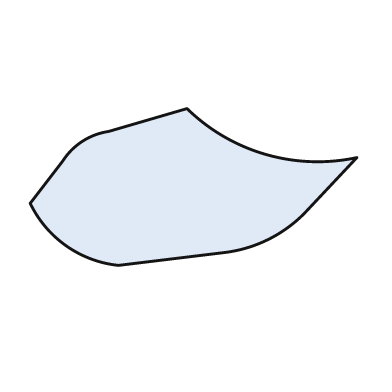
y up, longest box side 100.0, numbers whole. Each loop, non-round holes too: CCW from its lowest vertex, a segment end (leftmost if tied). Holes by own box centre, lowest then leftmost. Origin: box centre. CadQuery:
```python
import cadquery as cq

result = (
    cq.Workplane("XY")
    .moveTo(-23.0, -24.0)
    .lineTo(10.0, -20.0)
    .threePointArc((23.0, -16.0), (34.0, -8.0))
    .lineTo(50.0, 9.0)
    .threePointArc((22.0, 10.0), (-2.0, 24.0))
    .lineTo(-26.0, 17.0)
    .threePointArc((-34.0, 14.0), (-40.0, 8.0))
    .lineTo(-50.0, -5.0)
    .threePointArc((-39.0, -18.0), (-23.0, -24.0))
    .close()
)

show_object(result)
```